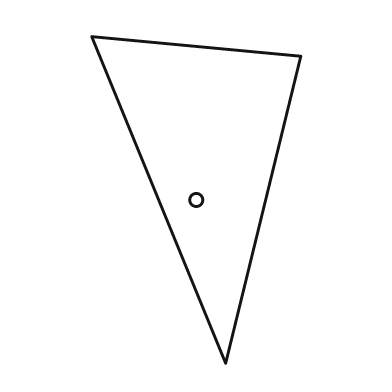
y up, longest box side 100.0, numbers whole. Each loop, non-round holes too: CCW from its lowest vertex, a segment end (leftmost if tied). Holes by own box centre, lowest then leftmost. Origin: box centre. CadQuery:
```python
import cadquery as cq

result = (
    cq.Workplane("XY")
    .moveTo(9.0, -50.0)
    .lineTo(32.0, 44.0)
    .lineTo(-32.0, 50.0)
    .close()
    .moveTo(0.0, 0.0)
    .circle(2.0)
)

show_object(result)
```